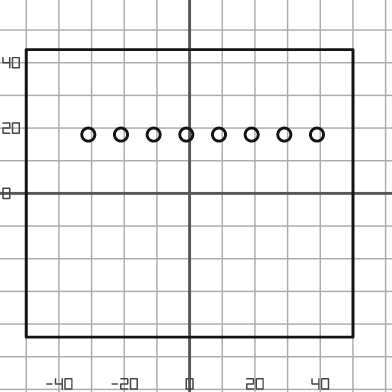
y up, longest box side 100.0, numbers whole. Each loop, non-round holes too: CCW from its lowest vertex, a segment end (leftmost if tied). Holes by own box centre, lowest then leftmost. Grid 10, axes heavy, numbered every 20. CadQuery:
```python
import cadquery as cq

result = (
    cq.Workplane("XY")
    .moveTo(-50.0, -44.0)
    .lineTo(50.0, -44.0)
    .lineTo(50.0, 44.0)
    .lineTo(-50.0, 44.0)
    .close()
    .moveTo(-31.0, 18.0)
    .circle(2.0)
    .moveTo(-21.0, 18.0)
    .circle(2.0)
    .moveTo(-11.0, 18.0)
    .circle(2.0)
    .moveTo(-1.0, 18.0)
    .circle(2.0)
    .moveTo(9.0, 18.0)
    .circle(2.0)
    .moveTo(19.0, 18.0)
    .circle(2.0)
    .moveTo(29.0, 18.0)
    .circle(2.0)
    .moveTo(39.0, 18.0)
    .circle(2.0)
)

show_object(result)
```